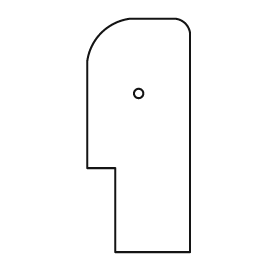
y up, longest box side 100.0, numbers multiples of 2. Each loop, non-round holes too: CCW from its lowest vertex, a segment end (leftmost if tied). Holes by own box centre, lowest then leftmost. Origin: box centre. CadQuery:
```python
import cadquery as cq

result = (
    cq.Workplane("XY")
    .moveTo(-10.0, -50.0)
    .lineTo(22.0, -50.0)
    .lineTo(22.0, 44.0)
    .threePointArc((20.0, 48.0), (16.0, 50.0))
    .lineTo(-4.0, 50.0)
    .threePointArc((-16.0, 44.0), (-22.0, 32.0))
    .lineTo(-22.0, -14.0)
    .lineTo(-10.0, -14.0)
    .close()
    .moveTo(0.0, 18.0)
    .circle(2.0)
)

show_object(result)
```